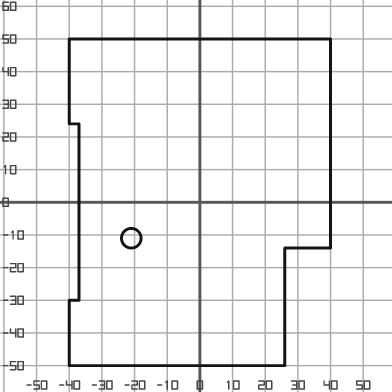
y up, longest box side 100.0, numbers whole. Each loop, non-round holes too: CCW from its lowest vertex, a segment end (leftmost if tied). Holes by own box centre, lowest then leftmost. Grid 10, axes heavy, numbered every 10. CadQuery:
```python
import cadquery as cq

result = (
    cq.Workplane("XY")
    .moveTo(-40.0, -50.0)
    .lineTo(26.0, -50.0)
    .lineTo(26.0, -14.0)
    .lineTo(40.0, -14.0)
    .lineTo(40.0, 50.0)
    .lineTo(-40.0, 50.0)
    .lineTo(-40.0, 24.0)
    .lineTo(-37.0, 24.0)
    .lineTo(-37.0, -30.0)
    .lineTo(-40.0, -30.0)
    .close()
    .moveTo(-21.0, -11.0)
    .circle(3.0)
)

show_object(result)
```